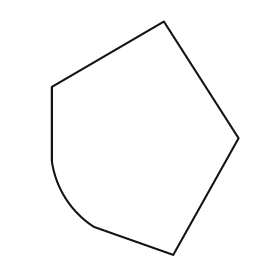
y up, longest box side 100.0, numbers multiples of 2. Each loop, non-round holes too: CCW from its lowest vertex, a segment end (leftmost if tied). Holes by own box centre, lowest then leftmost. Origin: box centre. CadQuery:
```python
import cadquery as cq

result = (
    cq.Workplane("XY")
    .moveTo(12.0, -50.0)
    .lineTo(40.0, 0.0)
    .lineTo(8.0, 50.0)
    .lineTo(-40.0, 22.0)
    .lineTo(-40.0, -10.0)
    .threePointArc((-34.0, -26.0), (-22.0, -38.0))
    .close()
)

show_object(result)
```